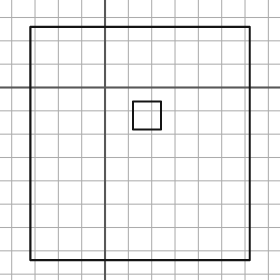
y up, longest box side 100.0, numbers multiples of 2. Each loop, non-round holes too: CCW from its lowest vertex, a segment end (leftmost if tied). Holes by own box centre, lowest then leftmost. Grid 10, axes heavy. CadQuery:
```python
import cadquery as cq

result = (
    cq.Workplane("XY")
    .moveTo(-32.0, -74.0)
    .lineTo(62.0, -74.0)
    .lineTo(62.0, 26.0)
    .lineTo(-32.0, 26.0)
    .close()
    .moveTo(12.0, -18.0)
    .lineTo(24.0, -18.0)
    .lineTo(24.0, -6.0)
    .lineTo(12.0, -6.0)
    .close()
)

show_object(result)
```